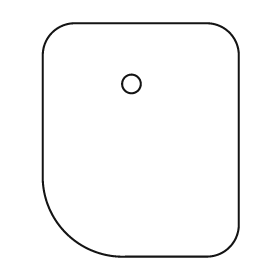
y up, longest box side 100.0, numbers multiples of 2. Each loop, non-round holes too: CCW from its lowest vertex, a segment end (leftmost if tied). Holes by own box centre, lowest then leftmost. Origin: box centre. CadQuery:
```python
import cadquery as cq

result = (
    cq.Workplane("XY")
    .moveTo(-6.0, -50.0)
    .lineTo(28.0, -50.0)
    .threePointArc((38.0, -46.0), (42.0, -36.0))
    .lineTo(42.0, 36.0)
    .threePointArc((38.0, 46.0), (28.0, 50.0))
    .lineTo(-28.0, 50.0)
    .threePointArc((-38.0, 46.0), (-42.0, 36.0))
    .lineTo(-42.0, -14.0)
    .threePointArc((-32.0, -40.0), (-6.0, -50.0))
    .close()
    .moveTo(-4.0, 24.0)
    .circle(4.0)
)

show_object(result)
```